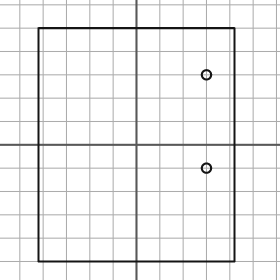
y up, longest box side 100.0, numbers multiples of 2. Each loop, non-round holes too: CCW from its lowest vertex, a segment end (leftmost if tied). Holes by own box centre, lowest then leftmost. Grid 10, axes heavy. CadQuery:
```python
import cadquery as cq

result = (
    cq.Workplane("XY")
    .moveTo(-42.0, -50.0)
    .lineTo(42.0, -50.0)
    .lineTo(42.0, 50.0)
    .lineTo(-42.0, 50.0)
    .close()
    .moveTo(30.0, -10.0)
    .circle(2.0)
    .moveTo(30.0, 30.0)
    .circle(2.0)
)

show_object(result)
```